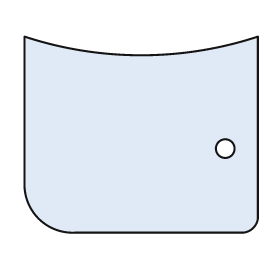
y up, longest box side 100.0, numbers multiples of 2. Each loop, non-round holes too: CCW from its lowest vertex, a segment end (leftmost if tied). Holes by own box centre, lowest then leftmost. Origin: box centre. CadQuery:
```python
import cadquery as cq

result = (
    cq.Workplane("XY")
    .moveTo(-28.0, -42.0)
    .lineTo(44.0, -42.0)
    .threePointArc((48.0, -40.0), (50.0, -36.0))
    .lineTo(50.0, 42.0)
    .threePointArc((0.0, 34.0), (-50.0, 42.0))
    .lineTo(-50.0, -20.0)
    .threePointArc((-44.0, -36.0), (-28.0, -42.0))
    .close()
    .moveTo(36.0, -6.0)
    .circle(4.0)
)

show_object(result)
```